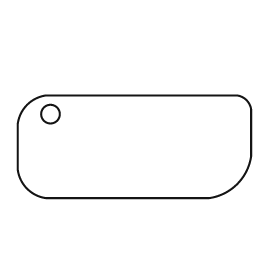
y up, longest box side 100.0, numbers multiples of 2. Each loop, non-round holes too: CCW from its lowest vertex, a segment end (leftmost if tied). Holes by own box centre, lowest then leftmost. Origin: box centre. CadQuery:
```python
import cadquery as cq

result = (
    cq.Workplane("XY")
    .moveTo(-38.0, -22.0)
    .lineTo(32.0, -22.0)
    .threePointArc((44.0, -16.0), (50.0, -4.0))
    .lineTo(50.0, 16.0)
    .threePointArc((48.0, 20.0), (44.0, 22.0))
    .lineTo(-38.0, 22.0)
    .threePointArc((-46.0, 18.0), (-50.0, 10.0))
    .lineTo(-50.0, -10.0)
    .threePointArc((-46.0, -18.0), (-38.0, -22.0))
    .close()
    .moveTo(-36.0, 14.0)
    .circle(4.0)
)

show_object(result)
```